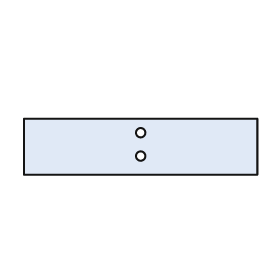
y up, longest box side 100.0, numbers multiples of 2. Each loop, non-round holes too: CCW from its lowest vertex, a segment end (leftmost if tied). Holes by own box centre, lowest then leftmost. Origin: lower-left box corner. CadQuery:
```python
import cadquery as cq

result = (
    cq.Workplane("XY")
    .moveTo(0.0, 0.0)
    .lineTo(100.0, 0.0)
    .lineTo(100.0, 24.0)
    .lineTo(0.0, 24.0)
    .close()
    .moveTo(50.0, 8.0)
    .circle(2.0)
    .moveTo(50.0, 18.0)
    .circle(2.0)
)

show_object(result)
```